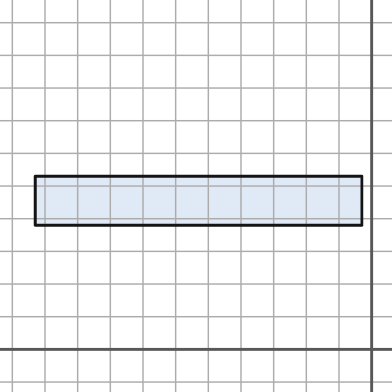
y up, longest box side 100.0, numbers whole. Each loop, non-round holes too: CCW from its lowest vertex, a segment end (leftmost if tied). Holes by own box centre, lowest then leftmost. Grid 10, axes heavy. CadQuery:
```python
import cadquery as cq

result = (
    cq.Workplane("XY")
    .moveTo(-103.0, 38.0)
    .lineTo(-3.0, 38.0)
    .lineTo(-3.0, 53.0)
    .lineTo(-103.0, 53.0)
    .close()
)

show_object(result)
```